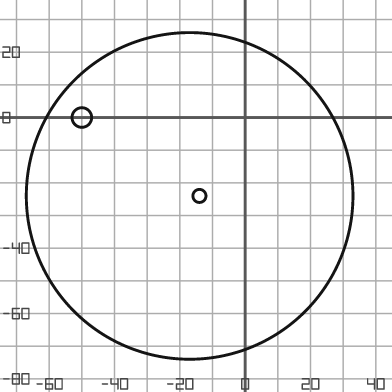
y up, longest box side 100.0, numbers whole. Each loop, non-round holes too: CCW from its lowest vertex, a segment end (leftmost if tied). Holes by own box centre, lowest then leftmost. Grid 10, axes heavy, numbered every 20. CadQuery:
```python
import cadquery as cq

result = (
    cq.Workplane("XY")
    .moveTo(-17.0, -24.0)
    .circle(50.0)
    .moveTo(-14.0, -24.0)
    .circle(2.0)
    .moveTo(-50.0, 0.0)
    .circle(3.0)
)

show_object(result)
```